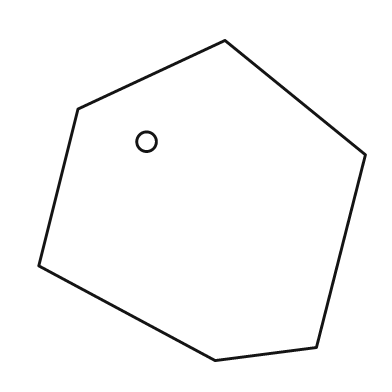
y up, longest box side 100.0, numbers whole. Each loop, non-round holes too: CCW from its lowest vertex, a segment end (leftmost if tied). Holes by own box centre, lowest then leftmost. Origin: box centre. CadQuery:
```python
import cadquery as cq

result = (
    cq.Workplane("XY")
    .moveTo(4.0, -49.0)
    .lineTo(35.0, -45.0)
    .lineTo(50.0, 14.0)
    .lineTo(7.0, 49.0)
    .lineTo(-38.0, 28.0)
    .lineTo(-50.0, -20.0)
    .close()
    .moveTo(-17.0, 18.0)
    .circle(3.0)
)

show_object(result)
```